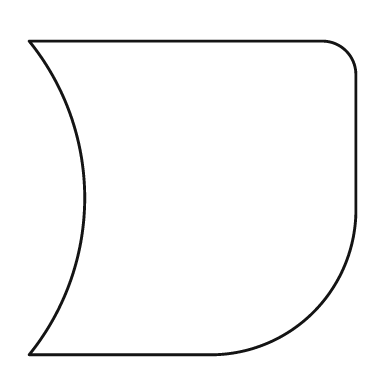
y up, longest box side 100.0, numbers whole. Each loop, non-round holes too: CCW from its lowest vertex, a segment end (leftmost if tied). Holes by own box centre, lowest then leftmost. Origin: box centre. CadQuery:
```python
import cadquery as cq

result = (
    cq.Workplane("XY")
    .moveTo(-50.0, -48.0)
    .lineTo(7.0, -48.0)
    .threePointArc((37.0, -35.0), (50.0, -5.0))
    .lineTo(50.0, 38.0)
    .threePointArc((47.0, 45.0), (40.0, 48.0))
    .lineTo(-50.0, 48.0)
    .threePointArc((-33.0, 0.0), (-50.0, -48.0))
    .close()
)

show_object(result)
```